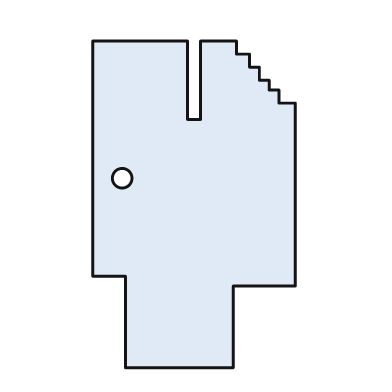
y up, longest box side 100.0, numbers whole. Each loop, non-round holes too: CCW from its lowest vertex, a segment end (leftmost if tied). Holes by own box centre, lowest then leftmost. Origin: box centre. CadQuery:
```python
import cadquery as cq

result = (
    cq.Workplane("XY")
    .moveTo(-21.0, -50.0)
    .lineTo(12.0, -50.0)
    .lineTo(12.0, -25.0)
    .lineTo(31.0, -25.0)
    .lineTo(31.0, 31.0)
    .lineTo(26.0, 31.0)
    .lineTo(26.0, 35.0)
    .lineTo(23.0, 35.0)
    .lineTo(23.0, 38.0)
    .lineTo(20.0, 38.0)
    .lineTo(20.0, 42.0)
    .lineTo(17.0, 42.0)
    .lineTo(17.0, 46.0)
    .lineTo(13.0, 46.0)
    .lineTo(13.0, 50.0)
    .lineTo(2.0, 50.0)
    .lineTo(2.0, 26.0)
    .lineTo(-2.0, 26.0)
    .lineTo(-2.0, 50.0)
    .lineTo(-31.0, 50.0)
    .lineTo(-31.0, -22.0)
    .lineTo(-21.0, -22.0)
    .close()
    .moveTo(-22.0, 8.0)
    .circle(3.0)
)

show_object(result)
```